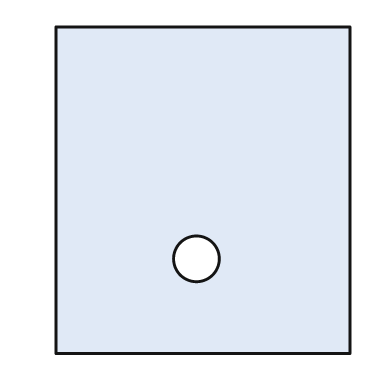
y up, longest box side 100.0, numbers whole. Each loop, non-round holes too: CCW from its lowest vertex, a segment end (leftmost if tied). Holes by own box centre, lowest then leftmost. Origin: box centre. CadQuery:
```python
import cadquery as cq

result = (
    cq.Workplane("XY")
    .moveTo(-45.0, -50.0)
    .lineTo(45.0, -50.0)
    .lineTo(45.0, 50.0)
    .lineTo(-45.0, 50.0)
    .close()
    .moveTo(-2.0, -21.0)
    .circle(7.0)
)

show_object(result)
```